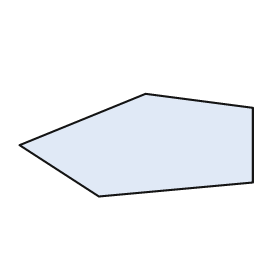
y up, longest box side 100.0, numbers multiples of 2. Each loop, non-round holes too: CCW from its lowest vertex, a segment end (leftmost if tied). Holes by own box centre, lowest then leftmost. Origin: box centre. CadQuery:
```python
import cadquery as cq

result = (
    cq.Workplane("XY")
    .moveTo(-16.0, -22.0)
    .lineTo(50.0, -16.0)
    .lineTo(50.0, 16.0)
    .lineTo(4.0, 22.0)
    .lineTo(-50.0, 0.0)
    .close()
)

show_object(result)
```